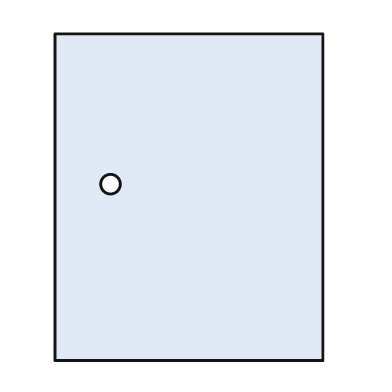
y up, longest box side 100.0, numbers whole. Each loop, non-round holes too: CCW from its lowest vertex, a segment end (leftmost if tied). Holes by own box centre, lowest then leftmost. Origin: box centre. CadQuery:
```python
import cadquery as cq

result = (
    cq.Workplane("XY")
    .moveTo(-41.0, -50.0)
    .lineTo(41.0, -50.0)
    .lineTo(41.0, 50.0)
    .lineTo(-41.0, 50.0)
    .close()
    .moveTo(-24.0, 4.0)
    .circle(3.0)
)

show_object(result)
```